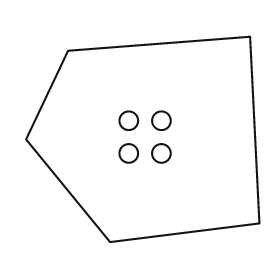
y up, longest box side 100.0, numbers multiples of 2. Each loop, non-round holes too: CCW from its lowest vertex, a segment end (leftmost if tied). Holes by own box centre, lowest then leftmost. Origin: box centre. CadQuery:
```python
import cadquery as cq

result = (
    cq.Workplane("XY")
    .moveTo(-14.0, -44.0)
    .lineTo(50.0, -36.0)
    .lineTo(46.0, 44.0)
    .lineTo(-32.0, 38.0)
    .lineTo(-50.0, 0.0)
    .close()
    .moveTo(-6.0, -6.0)
    .circle(4.0)
    .moveTo(8.0, -6.0)
    .circle(4.0)
    .moveTo(-6.0, 8.0)
    .circle(4.0)
    .moveTo(8.0, 8.0)
    .circle(4.0)
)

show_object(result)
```